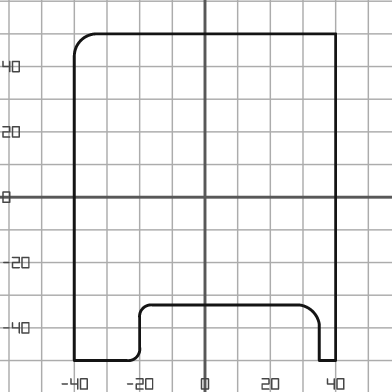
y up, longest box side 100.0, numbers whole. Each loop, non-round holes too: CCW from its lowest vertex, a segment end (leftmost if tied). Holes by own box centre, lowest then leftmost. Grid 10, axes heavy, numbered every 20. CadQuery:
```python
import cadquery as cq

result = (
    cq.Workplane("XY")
    .moveTo(-40.0, -50.0)
    .lineTo(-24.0, -50.0)
    .threePointArc((-21.0, -49.0), (-20.0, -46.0))
    .lineTo(-20.0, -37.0)
    .threePointArc((-19.0, -34.0), (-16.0, -33.0))
    .lineTo(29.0, -33.0)
    .threePointArc((33.0, -35.0), (35.0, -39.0))
    .lineTo(35.0, -50.0)
    .lineTo(40.0, -50.0)
    .lineTo(40.0, 50.0)
    .lineTo(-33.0, 50.0)
    .threePointArc((-38.0, 48.0), (-40.0, 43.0))
    .close()
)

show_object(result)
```